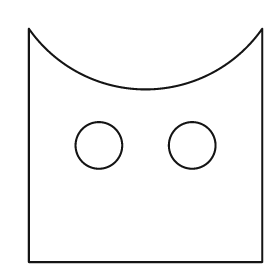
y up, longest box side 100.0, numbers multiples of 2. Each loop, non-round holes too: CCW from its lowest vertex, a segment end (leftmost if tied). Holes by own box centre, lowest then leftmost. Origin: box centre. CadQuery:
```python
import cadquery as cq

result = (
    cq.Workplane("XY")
    .moveTo(-50.0, -50.0)
    .lineTo(50.0, -50.0)
    .lineTo(50.0, 50.0)
    .threePointArc((0.0, 24.0), (-50.0, 50.0))
    .close()
    .moveTo(-20.0, 0.0)
    .circle(10.0)
    .moveTo(20.0, 0.0)
    .circle(10.0)
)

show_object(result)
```